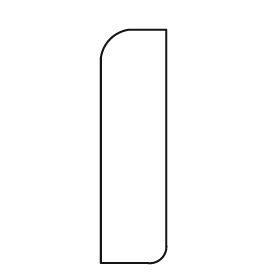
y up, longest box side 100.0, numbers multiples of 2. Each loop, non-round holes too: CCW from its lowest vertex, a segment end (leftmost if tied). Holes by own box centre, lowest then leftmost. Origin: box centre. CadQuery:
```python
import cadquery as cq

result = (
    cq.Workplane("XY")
    .moveTo(-14.0, -50.0)
    .lineTo(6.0, -50.0)
    .threePointArc((12.0, -48.0), (14.0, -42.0))
    .lineTo(14.0, 50.0)
    .lineTo(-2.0, 50.0)
    .threePointArc((-10.0, 46.0), (-14.0, 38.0))
    .close()
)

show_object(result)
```